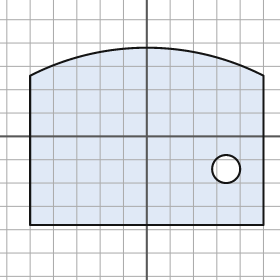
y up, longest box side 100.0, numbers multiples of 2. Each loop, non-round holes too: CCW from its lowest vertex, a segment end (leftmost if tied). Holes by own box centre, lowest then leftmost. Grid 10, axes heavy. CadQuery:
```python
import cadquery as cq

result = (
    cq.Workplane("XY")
    .moveTo(-50.0, -38.0)
    .lineTo(50.0, -38.0)
    .lineTo(50.0, 26.0)
    .threePointArc((0.0, 38.0), (-50.0, 26.0))
    .close()
    .moveTo(34.0, -14.0)
    .circle(6.0)
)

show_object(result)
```